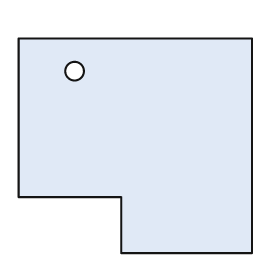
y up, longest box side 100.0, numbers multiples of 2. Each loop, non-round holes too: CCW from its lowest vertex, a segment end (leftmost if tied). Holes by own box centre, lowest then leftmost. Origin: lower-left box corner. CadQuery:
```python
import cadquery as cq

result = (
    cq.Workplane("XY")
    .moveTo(44.0, 0.0)
    .lineTo(100.0, 0.0)
    .lineTo(100.0, 92.0)
    .lineTo(0.0, 92.0)
    .lineTo(0.0, 24.0)
    .lineTo(44.0, 24.0)
    .close()
    .moveTo(24.0, 78.0)
    .circle(4.0)
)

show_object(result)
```